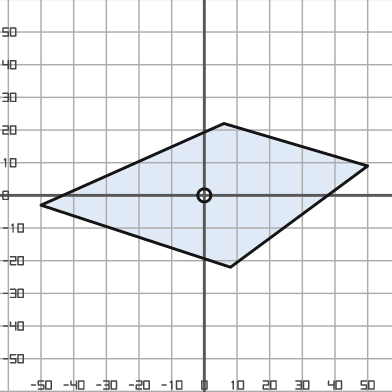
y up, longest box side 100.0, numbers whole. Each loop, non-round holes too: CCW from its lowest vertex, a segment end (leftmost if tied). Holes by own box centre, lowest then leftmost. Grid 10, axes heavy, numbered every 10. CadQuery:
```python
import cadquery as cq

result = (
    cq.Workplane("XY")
    .moveTo(8.0, -22.0)
    .lineTo(50.0, 9.0)
    .lineTo(6.0, 22.0)
    .lineTo(-50.0, -3.0)
    .close()
    .moveTo(0.0, 0.0)
    .circle(2.0)
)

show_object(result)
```